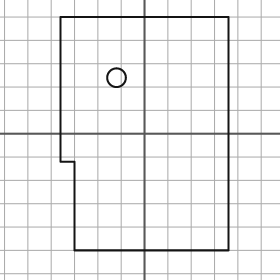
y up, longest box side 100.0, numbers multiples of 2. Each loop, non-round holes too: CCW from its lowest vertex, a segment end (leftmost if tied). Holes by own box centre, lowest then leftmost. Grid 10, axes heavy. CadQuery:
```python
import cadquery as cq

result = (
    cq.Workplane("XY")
    .moveTo(-30.0, -50.0)
    .lineTo(36.0, -50.0)
    .lineTo(36.0, 50.0)
    .lineTo(-36.0, 50.0)
    .lineTo(-36.0, -12.0)
    .lineTo(-30.0, -12.0)
    .close()
    .moveTo(-12.0, 24.0)
    .circle(4.0)
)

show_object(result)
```